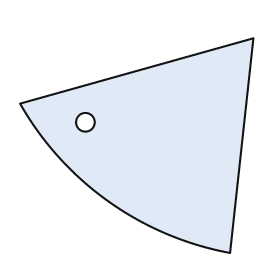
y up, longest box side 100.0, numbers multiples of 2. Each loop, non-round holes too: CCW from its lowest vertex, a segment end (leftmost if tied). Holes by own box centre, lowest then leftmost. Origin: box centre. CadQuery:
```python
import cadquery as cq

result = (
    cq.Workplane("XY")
    .moveTo(40.0, -46.0)
    .lineTo(50.0, 46.0)
    .lineTo(-50.0, 18.0)
    .threePointArc((-12.0, -24.0), (40.0, -46.0))
    .close()
    .moveTo(-22.0, 10.0)
    .circle(4.0)
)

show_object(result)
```